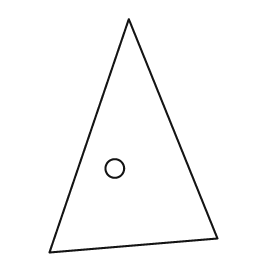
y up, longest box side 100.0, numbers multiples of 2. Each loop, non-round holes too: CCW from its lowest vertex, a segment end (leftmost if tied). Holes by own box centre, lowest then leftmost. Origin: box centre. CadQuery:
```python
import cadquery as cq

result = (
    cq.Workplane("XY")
    .moveTo(-36.0, -50.0)
    .lineTo(36.0, -44.0)
    .lineTo(-2.0, 50.0)
    .close()
    .moveTo(-8.0, -14.0)
    .circle(4.0)
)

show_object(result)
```